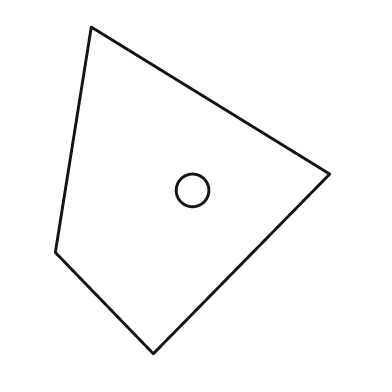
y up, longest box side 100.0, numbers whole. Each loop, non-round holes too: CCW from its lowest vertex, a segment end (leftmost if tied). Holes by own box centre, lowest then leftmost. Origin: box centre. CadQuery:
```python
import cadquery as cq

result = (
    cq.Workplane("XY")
    .moveTo(-12.0, -50.0)
    .lineTo(42.0, 5.0)
    .lineTo(-31.0, 50.0)
    .lineTo(-42.0, -19.0)
    .close()
    .moveTo(0.0, 0.0)
    .circle(5.0)
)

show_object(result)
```